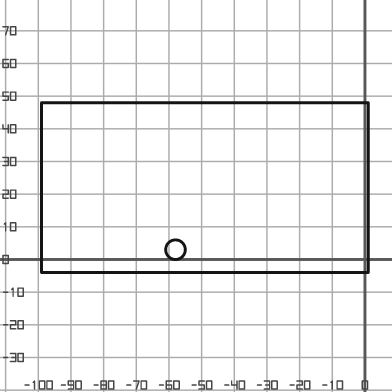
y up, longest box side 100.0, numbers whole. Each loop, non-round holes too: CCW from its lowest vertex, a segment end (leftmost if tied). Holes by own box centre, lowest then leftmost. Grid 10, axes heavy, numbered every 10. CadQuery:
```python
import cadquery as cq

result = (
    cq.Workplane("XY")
    .moveTo(-99.0, -4.0)
    .lineTo(1.0, -4.0)
    .lineTo(1.0, 48.0)
    .lineTo(-99.0, 48.0)
    .close()
    .moveTo(-58.0, 3.0)
    .circle(3.0)
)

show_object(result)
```